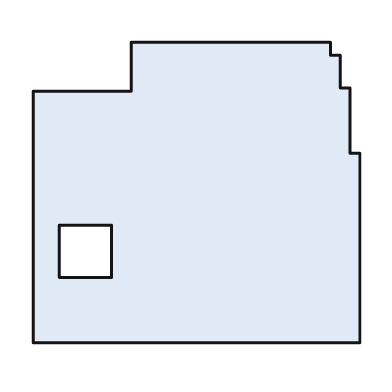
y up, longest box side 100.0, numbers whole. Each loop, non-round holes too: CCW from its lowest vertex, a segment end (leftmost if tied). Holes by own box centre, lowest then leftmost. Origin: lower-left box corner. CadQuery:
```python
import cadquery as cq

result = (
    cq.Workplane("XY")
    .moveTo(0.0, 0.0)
    .lineTo(100.0, 0.0)
    .lineTo(100.0, 58.0)
    .lineTo(97.0, 58.0)
    .lineTo(97.0, 78.0)
    .lineTo(94.0, 78.0)
    .lineTo(94.0, 88.0)
    .lineTo(91.0, 88.0)
    .lineTo(91.0, 92.0)
    .lineTo(30.0, 92.0)
    .lineTo(30.0, 77.0)
    .lineTo(0.0, 77.0)
    .close()
    .moveTo(8.0, 20.0)
    .lineTo(24.0, 20.0)
    .lineTo(24.0, 36.0)
    .lineTo(8.0, 36.0)
    .close()
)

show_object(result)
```